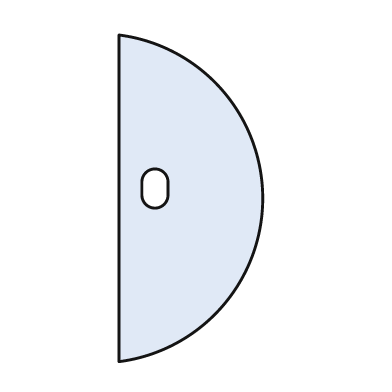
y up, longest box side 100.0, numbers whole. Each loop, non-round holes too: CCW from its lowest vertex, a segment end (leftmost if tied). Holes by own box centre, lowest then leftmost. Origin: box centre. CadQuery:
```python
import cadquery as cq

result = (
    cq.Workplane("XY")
    .moveTo(-22.0, -50.0)
    .threePointArc((22.0, 0.0), (-22.0, 50.0))
    .close()
    .moveTo(-15.0, 1.0)
    .threePointArc((-11.0, -3.0), (-7.0, 1.0))
    .lineTo(-7.0, 5.0)
    .threePointArc((-11.0, 9.0), (-15.0, 5.0))
    .close()
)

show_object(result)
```